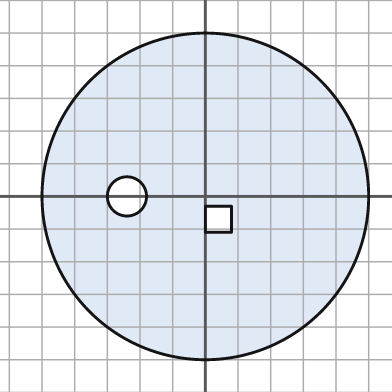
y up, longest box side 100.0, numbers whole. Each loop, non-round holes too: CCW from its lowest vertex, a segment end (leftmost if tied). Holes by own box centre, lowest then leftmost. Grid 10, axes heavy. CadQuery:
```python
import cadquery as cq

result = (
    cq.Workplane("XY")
    .moveTo(0.0, 0.0)
    .circle(50.0)
    .moveTo(0.0, -11.0)
    .lineTo(8.0, -11.0)
    .lineTo(8.0, -3.0)
    .lineTo(0.0, -3.0)
    .close()
    .moveTo(-24.0, 0.0)
    .circle(6.0)
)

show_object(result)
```